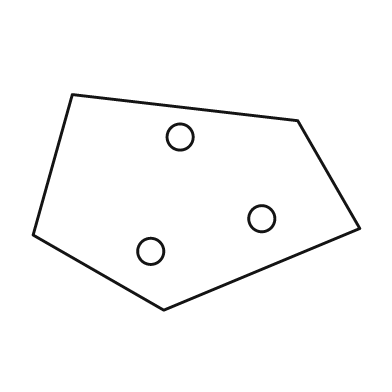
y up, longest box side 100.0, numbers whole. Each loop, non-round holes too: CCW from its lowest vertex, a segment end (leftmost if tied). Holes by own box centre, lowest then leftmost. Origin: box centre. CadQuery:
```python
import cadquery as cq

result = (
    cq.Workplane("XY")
    .moveTo(-10.0, -33.0)
    .lineTo(50.0, -8.0)
    .lineTo(31.0, 25.0)
    .lineTo(-38.0, 33.0)
    .lineTo(-50.0, -10.0)
    .close()
    .moveTo(-14.0, -15.0)
    .circle(4.0)
    .moveTo(20.0, -5.0)
    .circle(4.0)
    .moveTo(-5.0, 20.0)
    .circle(4.0)
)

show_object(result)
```